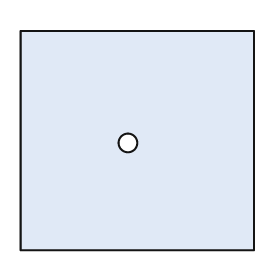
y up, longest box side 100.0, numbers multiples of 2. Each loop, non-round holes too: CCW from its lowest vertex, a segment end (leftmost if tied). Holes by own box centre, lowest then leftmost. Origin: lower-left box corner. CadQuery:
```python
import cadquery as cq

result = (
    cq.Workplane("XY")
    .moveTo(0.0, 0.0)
    .lineTo(100.0, 0.0)
    .lineTo(100.0, 94.0)
    .lineTo(0.0, 94.0)
    .close()
    .moveTo(46.0, 46.0)
    .circle(4.0)
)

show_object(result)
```